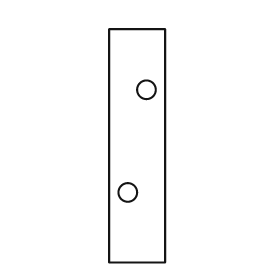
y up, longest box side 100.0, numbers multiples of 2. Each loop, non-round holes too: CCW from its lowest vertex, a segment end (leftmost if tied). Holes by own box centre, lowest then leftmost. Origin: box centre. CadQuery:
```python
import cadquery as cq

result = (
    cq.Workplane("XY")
    .moveTo(-12.0, -50.0)
    .lineTo(12.0, -50.0)
    .lineTo(12.0, 50.0)
    .lineTo(-12.0, 50.0)
    .close()
    .moveTo(-4.0, -20.0)
    .circle(4.0)
    .moveTo(4.0, 24.0)
    .circle(4.0)
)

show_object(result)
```